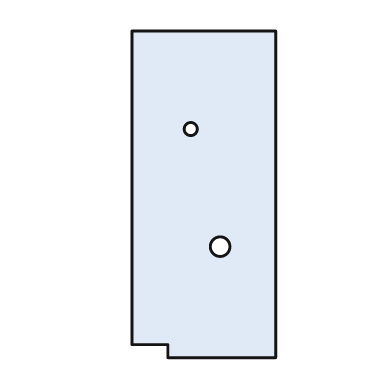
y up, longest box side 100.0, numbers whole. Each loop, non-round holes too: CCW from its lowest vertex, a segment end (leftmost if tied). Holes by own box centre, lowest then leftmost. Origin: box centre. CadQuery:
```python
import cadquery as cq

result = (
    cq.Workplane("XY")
    .moveTo(-11.0, -50.0)
    .lineTo(22.0, -50.0)
    .lineTo(22.0, 50.0)
    .lineTo(-22.0, 50.0)
    .lineTo(-22.0, -46.0)
    .lineTo(-11.0, -46.0)
    .close()
    .moveTo(5.0, -16.0)
    .circle(3.0)
    .moveTo(-4.0, 20.0)
    .circle(2.0)
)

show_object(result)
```